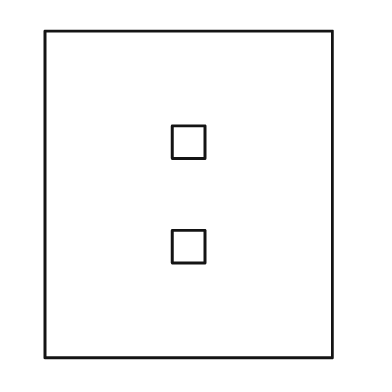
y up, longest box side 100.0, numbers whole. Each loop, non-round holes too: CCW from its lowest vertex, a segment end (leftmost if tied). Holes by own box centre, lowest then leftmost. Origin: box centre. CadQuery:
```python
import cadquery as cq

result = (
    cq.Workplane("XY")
    .moveTo(-44.0, -50.0)
    .lineTo(44.0, -50.0)
    .lineTo(44.0, 50.0)
    .lineTo(-44.0, 50.0)
    .close()
    .moveTo(-5.0, -21.0)
    .lineTo(5.0, -21.0)
    .lineTo(5.0, -11.0)
    .lineTo(-5.0, -11.0)
    .close()
    .moveTo(-5.0, 11.0)
    .lineTo(5.0, 11.0)
    .lineTo(5.0, 21.0)
    .lineTo(-5.0, 21.0)
    .close()
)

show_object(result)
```